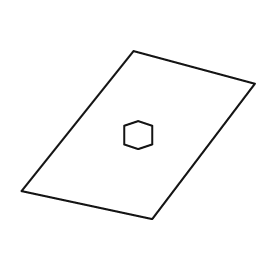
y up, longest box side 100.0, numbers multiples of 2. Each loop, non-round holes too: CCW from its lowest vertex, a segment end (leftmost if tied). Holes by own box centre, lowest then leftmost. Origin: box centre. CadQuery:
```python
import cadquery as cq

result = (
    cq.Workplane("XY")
    .moveTo(6.0, -36.0)
    .lineTo(50.0, 22.0)
    .lineTo(-2.0, 36.0)
    .lineTo(-50.0, -24.0)
    .close()
    .moveTo(0.0, -6.0)
    .lineTo(6.0, -4.0)
    .lineTo(6.0, 4.0)
    .lineTo(0.0, 6.0)
    .lineTo(-6.0, 4.0)
    .lineTo(-6.0, -4.0)
    .close()
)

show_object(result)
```